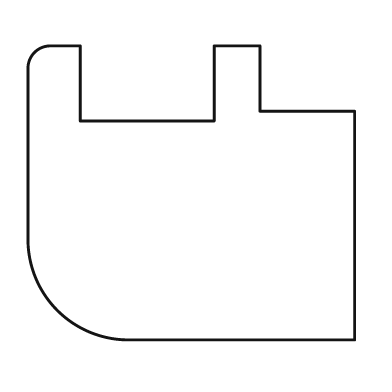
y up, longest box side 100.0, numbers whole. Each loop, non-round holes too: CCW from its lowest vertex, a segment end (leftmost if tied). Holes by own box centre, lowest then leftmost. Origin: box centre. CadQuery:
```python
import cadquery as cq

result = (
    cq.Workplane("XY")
    .moveTo(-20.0, -45.0)
    .lineTo(50.0, -45.0)
    .lineTo(50.0, 25.0)
    .lineTo(21.0, 25.0)
    .lineTo(21.0, 45.0)
    .lineTo(7.0, 45.0)
    .lineTo(7.0, 22.0)
    .lineTo(-34.0, 22.0)
    .lineTo(-34.0, 45.0)
    .lineTo(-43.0, 45.0)
    .threePointArc((-48.0, 43.0), (-50.0, 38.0))
    .lineTo(-50.0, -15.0)
    .threePointArc((-41.0, -36.0), (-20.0, -45.0))
    .close()
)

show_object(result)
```